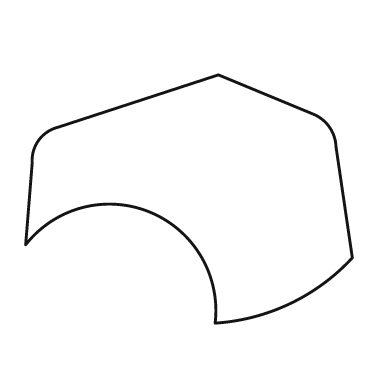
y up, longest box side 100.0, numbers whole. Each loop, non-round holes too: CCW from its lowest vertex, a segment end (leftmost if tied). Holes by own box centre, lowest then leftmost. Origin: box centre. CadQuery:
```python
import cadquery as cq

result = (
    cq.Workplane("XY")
    .moveTo(8.0, -38.0)
    .threePointArc((31.0, -32.0), (50.0, -18.0))
    .lineTo(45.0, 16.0)
    .threePointArc((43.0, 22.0), (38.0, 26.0))
    .lineTo(9.0, 38.0)
    .lineTo(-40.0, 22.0)
    .threePointArc((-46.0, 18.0), (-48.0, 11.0))
    .lineTo(-50.0, -14.0)
    .threePointArc((-12.0, -4.0), (8.0, -38.0))
    .close()
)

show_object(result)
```